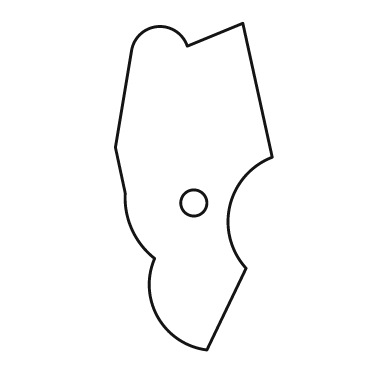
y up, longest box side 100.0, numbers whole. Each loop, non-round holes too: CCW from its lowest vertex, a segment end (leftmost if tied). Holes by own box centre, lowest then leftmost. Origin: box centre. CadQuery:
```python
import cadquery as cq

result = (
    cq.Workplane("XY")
    .moveTo(4.0, -50.0)
    .lineTo(16.0, -25.0)
    .threePointArc((11.0, -6.0), (24.0, 9.0))
    .lineTo(15.0, 50.0)
    .lineTo(-2.0, 43.0)
    .threePointArc((-11.0, 49.0), (-19.0, 42.0))
    .lineTo(-24.0, 12.0)
    .lineTo(-21.0, -2.0)
    .threePointArc((-19.0, -13.0), (-12.0, -22.0))
    .threePointArc((-11.0, -40.0), (4.0, -50.0))
    .close()
    .moveTo(0.0, -5.0)
    .circle(4.0)
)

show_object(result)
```